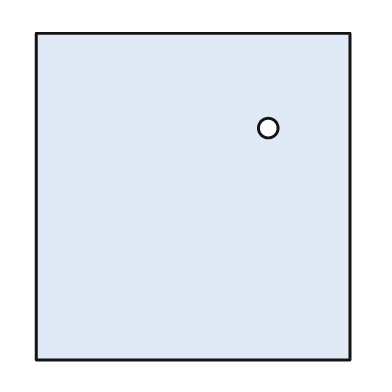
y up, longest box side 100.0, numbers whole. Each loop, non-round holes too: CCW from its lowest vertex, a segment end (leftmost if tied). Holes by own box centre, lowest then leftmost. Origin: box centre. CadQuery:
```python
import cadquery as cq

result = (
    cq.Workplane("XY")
    .moveTo(-48.0, -50.0)
    .lineTo(48.0, -50.0)
    .lineTo(48.0, 50.0)
    .lineTo(-48.0, 50.0)
    .close()
    .moveTo(23.0, 21.0)
    .circle(3.0)
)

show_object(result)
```